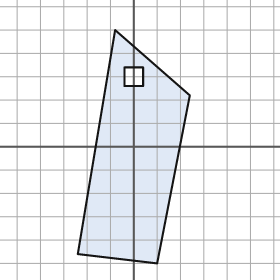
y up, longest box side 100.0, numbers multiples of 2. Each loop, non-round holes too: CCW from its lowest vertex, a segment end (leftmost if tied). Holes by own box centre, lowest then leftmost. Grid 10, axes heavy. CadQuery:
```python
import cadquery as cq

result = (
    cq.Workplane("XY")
    .moveTo(10.0, -50.0)
    .lineTo(24.0, 22.0)
    .lineTo(-8.0, 50.0)
    .lineTo(-24.0, -46.0)
    .close()
    .moveTo(-4.0, 26.0)
    .lineTo(4.0, 26.0)
    .lineTo(4.0, 34.0)
    .lineTo(-4.0, 34.0)
    .close()
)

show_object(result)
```